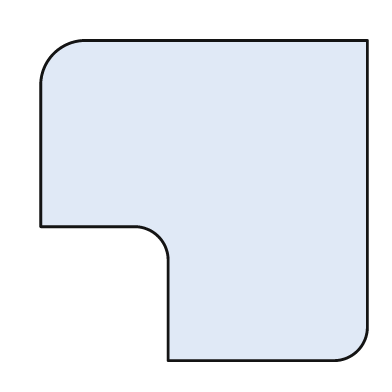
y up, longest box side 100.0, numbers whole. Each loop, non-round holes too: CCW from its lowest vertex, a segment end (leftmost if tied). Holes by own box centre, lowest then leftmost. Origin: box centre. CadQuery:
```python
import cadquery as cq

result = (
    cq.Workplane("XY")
    .moveTo(-11.0, -49.0)
    .lineTo(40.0, -49.0)
    .threePointArc((47.0, -46.0), (50.0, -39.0))
    .lineTo(50.0, 49.0)
    .lineTo(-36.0, 49.0)
    .threePointArc((-46.0, 45.0), (-50.0, 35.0))
    .lineTo(-50.0, -8.0)
    .lineTo(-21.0, -8.0)
    .threePointArc((-14.0, -11.0), (-11.0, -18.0))
    .close()
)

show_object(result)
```